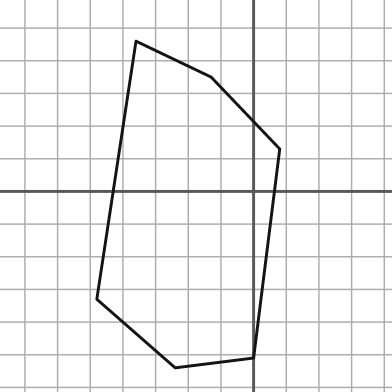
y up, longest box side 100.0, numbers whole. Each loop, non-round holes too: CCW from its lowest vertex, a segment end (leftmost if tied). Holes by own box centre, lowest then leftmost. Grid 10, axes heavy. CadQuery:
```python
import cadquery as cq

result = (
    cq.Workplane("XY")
    .moveTo(-24.0, -54.0)
    .lineTo(0.0, -51.0)
    .lineTo(8.0, 13.0)
    .lineTo(-13.0, 35.0)
    .lineTo(-36.0, 46.0)
    .lineTo(-48.0, -33.0)
    .close()
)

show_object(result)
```